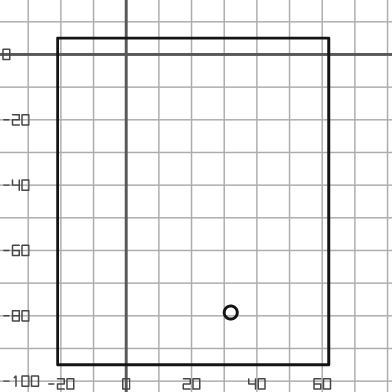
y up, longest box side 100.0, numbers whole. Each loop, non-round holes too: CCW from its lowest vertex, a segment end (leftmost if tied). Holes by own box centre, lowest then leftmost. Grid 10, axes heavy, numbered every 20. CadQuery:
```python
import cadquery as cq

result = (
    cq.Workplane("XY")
    .moveTo(-21.0, -95.0)
    .lineTo(62.0, -95.0)
    .lineTo(62.0, 5.0)
    .lineTo(-21.0, 5.0)
    .close()
    .moveTo(32.0, -79.0)
    .circle(2.0)
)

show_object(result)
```